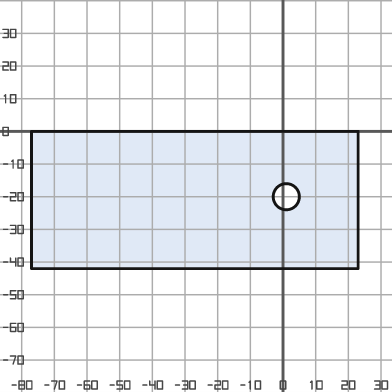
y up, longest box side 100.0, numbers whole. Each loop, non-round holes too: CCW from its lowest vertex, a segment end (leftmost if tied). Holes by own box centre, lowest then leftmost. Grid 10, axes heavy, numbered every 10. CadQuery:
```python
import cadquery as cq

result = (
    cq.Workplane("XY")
    .moveTo(-77.0, -42.0)
    .lineTo(23.0, -42.0)
    .lineTo(23.0, 0.0)
    .lineTo(-77.0, 0.0)
    .close()
    .moveTo(1.0, -20.0)
    .circle(4.0)
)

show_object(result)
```